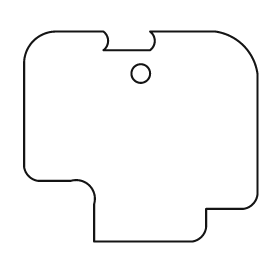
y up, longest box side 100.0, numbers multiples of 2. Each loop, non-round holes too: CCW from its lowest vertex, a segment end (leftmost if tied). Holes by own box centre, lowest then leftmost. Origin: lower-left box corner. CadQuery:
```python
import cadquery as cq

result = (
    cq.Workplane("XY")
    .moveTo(30.0, 0.0)
    .lineTo(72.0, 0.0)
    .threePointArc((76.0, 2.0), (78.0, 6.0))
    .lineTo(78.0, 14.0)
    .lineTo(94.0, 14.0)
    .threePointArc((98.0, 16.0), (100.0, 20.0))
    .lineTo(100.0, 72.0)
    .threePointArc((94.0, 84.0), (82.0, 90.0))
    .lineTo(54.0, 90.0)
    .threePointArc((56.0, 86.0), (54.0, 82.0))
    .lineTo(34.0, 82.0)
    .threePointArc((36.0, 86.0), (34.0, 90.0))
    .lineTo(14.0, 90.0)
    .threePointArc((4.0, 86.0), (0.0, 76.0))
    .lineTo(0.0, 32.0)
    .threePointArc((2.0, 28.0), (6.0, 26.0))
    .lineTo(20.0, 26.0)
    .threePointArc((28.0, 24.0), (30.0, 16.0))
    .close()
    .moveTo(50.0, 72.0)
    .circle(4.0)
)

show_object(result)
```